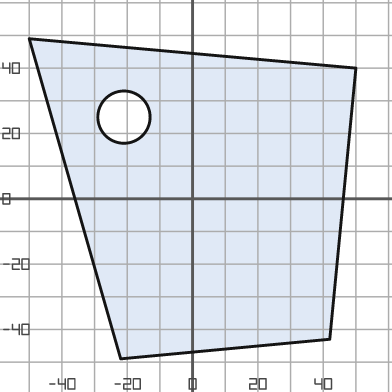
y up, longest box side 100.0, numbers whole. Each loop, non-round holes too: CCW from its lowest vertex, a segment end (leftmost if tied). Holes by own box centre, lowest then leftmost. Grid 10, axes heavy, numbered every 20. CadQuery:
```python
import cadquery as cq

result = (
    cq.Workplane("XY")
    .moveTo(-22.0, -49.0)
    .lineTo(42.0, -43.0)
    .lineTo(50.0, 40.0)
    .lineTo(-50.0, 49.0)
    .close()
    .moveTo(-21.0, 25.0)
    .circle(8.0)
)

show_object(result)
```